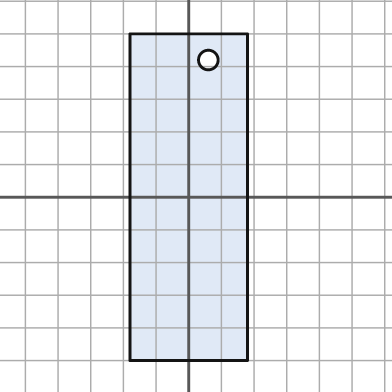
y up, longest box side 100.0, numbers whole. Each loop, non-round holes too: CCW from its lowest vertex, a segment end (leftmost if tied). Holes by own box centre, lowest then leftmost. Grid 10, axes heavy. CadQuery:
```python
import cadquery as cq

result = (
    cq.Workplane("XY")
    .moveTo(-18.0, -50.0)
    .lineTo(18.0, -50.0)
    .lineTo(18.0, 50.0)
    .lineTo(-18.0, 50.0)
    .close()
    .moveTo(6.0, 42.0)
    .circle(3.0)
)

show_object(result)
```